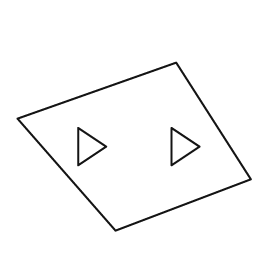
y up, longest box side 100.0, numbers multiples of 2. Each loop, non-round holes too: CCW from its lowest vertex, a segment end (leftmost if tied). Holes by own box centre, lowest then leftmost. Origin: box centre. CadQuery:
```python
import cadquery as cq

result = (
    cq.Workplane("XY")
    .moveTo(-8.0, -36.0)
    .lineTo(50.0, -14.0)
    .lineTo(18.0, 36.0)
    .lineTo(-50.0, 12.0)
    .close()
    .moveTo(-24.0, -8.0)
    .lineTo(-12.0, 0.0)
    .lineTo(-24.0, 8.0)
    .close()
    .moveTo(16.0, -8.0)
    .lineTo(28.0, 0.0)
    .lineTo(16.0, 8.0)
    .close()
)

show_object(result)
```